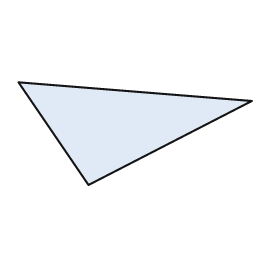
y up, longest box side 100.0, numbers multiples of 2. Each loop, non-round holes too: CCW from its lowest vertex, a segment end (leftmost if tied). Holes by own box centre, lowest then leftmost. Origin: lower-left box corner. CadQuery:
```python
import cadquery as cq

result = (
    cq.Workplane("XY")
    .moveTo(30.0, 0.0)
    .lineTo(100.0, 36.0)
    .lineTo(0.0, 44.0)
    .close()
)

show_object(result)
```